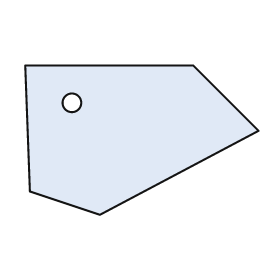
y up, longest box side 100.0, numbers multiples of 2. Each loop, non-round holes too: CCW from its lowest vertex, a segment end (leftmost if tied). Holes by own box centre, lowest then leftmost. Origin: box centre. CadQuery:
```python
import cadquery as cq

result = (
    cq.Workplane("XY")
    .moveTo(-18.0, -32.0)
    .lineTo(50.0, 4.0)
    .lineTo(22.0, 32.0)
    .lineTo(-50.0, 32.0)
    .lineTo(-48.0, -22.0)
    .close()
    .moveTo(-30.0, 16.0)
    .circle(4.0)
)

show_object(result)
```